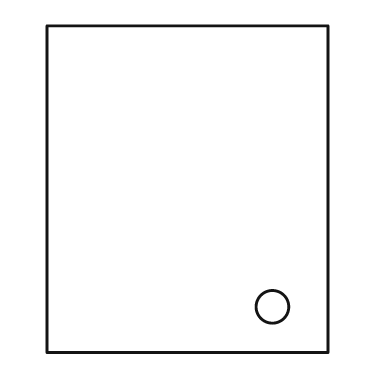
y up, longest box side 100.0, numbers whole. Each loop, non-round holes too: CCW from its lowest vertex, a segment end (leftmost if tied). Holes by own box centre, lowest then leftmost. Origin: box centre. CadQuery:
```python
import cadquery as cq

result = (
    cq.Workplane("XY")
    .moveTo(-43.0, -50.0)
    .lineTo(43.0, -50.0)
    .lineTo(43.0, 50.0)
    .lineTo(-43.0, 50.0)
    .close()
    .moveTo(26.0, -36.0)
    .circle(5.0)
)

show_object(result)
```